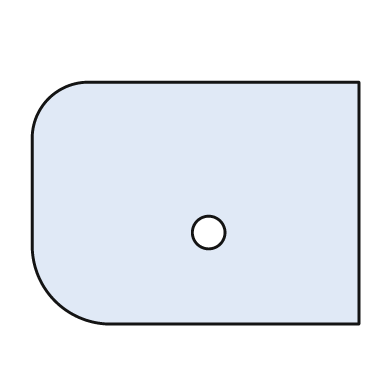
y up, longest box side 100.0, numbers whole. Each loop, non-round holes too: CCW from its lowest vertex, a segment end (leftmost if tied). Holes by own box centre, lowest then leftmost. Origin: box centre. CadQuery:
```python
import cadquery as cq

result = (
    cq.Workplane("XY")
    .moveTo(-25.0, -37.0)
    .lineTo(50.0, -37.0)
    .lineTo(50.0, 37.0)
    .lineTo(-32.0, 37.0)
    .threePointArc((-45.0, 32.0), (-50.0, 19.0))
    .lineTo(-50.0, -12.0)
    .threePointArc((-43.0, -30.0), (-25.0, -37.0))
    .close()
    .moveTo(4.0, -9.0)
    .circle(5.0)
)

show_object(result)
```